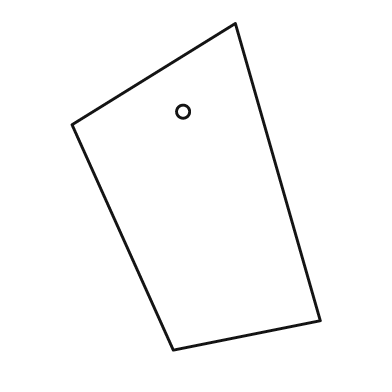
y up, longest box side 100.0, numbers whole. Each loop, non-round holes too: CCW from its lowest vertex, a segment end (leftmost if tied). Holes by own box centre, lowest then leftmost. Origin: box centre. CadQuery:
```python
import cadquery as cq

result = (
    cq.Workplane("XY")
    .moveTo(-7.0, -50.0)
    .lineTo(38.0, -41.0)
    .lineTo(12.0, 50.0)
    .lineTo(-38.0, 19.0)
    .close()
    .moveTo(-4.0, 23.0)
    .circle(2.0)
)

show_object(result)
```